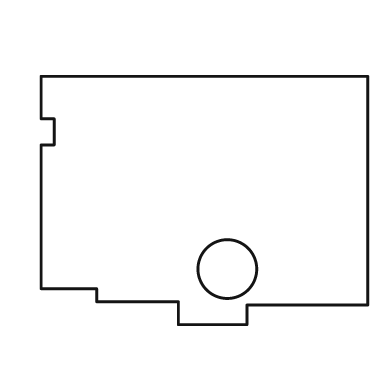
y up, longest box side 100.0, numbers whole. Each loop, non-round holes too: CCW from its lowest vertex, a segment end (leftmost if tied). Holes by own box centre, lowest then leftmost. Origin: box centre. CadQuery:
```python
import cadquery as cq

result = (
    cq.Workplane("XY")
    .moveTo(-8.0, -38.0)
    .lineTo(13.0, -38.0)
    .lineTo(13.0, -32.0)
    .lineTo(50.0, -32.0)
    .lineTo(50.0, 38.0)
    .lineTo(-50.0, 38.0)
    .lineTo(-50.0, 25.0)
    .lineTo(-46.0, 25.0)
    .lineTo(-46.0, 17.0)
    .lineTo(-50.0, 17.0)
    .lineTo(-50.0, -27.0)
    .lineTo(-33.0, -27.0)
    .lineTo(-33.0, -31.0)
    .lineTo(-8.0, -31.0)
    .close()
    .moveTo(7.0, -21.0)
    .circle(9.0)
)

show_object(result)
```